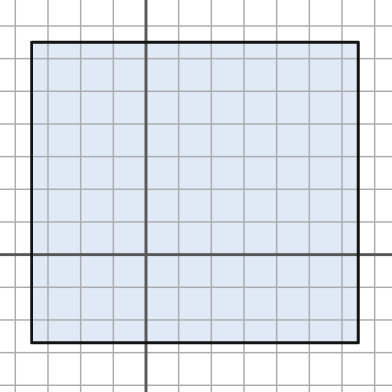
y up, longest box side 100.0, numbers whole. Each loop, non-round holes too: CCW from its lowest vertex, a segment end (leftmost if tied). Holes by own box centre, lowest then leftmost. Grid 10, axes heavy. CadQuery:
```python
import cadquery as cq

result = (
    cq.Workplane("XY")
    .moveTo(-35.0, -27.0)
    .lineTo(65.0, -27.0)
    .lineTo(65.0, 65.0)
    .lineTo(-35.0, 65.0)
    .close()
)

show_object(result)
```